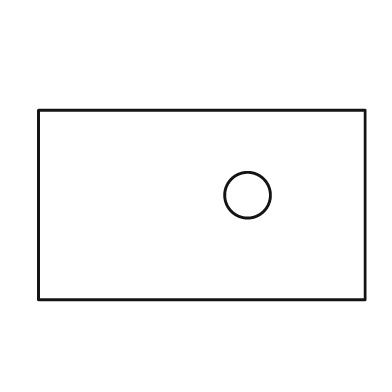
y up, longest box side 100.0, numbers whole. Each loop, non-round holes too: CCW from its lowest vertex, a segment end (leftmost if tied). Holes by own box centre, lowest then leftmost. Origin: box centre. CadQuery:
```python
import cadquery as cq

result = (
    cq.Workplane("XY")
    .moveTo(-50.0, -29.0)
    .lineTo(50.0, -29.0)
    .lineTo(50.0, 29.0)
    .lineTo(-50.0, 29.0)
    .close()
    .moveTo(14.0, 3.0)
    .circle(7.0)
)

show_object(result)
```